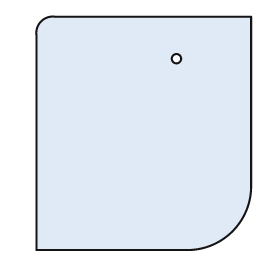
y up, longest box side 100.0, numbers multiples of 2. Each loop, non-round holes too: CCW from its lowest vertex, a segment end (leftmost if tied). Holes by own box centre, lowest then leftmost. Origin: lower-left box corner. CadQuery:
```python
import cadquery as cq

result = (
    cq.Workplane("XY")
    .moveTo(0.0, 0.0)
    .lineTo(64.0, 0.0)
    .threePointArc((84.0, 8.0), (92.0, 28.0))
    .lineTo(92.0, 100.0)
    .lineTo(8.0, 100.0)
    .threePointArc((2.0, 98.0), (0.0, 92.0))
    .close()
    .moveTo(60.0, 82.0)
    .circle(2.0)
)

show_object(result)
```